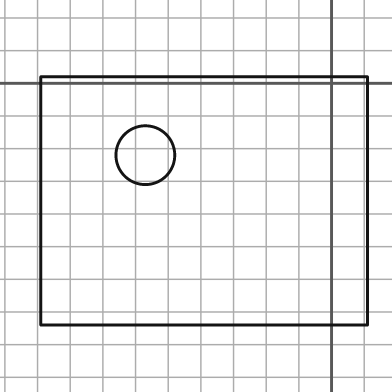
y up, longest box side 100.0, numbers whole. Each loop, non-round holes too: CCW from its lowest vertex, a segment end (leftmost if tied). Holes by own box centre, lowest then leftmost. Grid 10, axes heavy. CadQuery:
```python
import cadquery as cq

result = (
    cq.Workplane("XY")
    .moveTo(-89.0, -74.0)
    .lineTo(11.0, -74.0)
    .lineTo(11.0, 2.0)
    .lineTo(-89.0, 2.0)
    .close()
    .moveTo(-57.0, -22.0)
    .circle(9.0)
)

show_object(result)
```